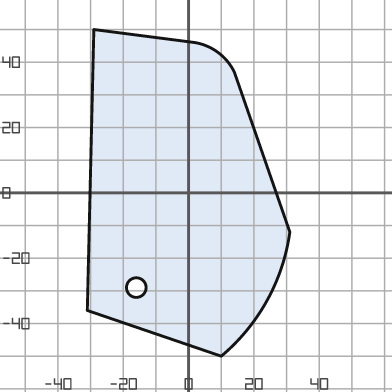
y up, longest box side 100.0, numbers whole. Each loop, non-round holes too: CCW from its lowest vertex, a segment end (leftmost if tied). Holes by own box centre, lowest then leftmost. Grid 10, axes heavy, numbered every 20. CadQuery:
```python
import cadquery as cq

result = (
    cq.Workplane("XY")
    .moveTo(10.0, -50.0)
    .threePointArc((24.0, -33.0), (31.0, -12.0))
    .lineTo(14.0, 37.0)
    .threePointArc((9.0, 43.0), (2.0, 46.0))
    .lineTo(-29.0, 50.0)
    .lineTo(-31.0, -36.0)
    .close()
    .moveTo(-16.0, -29.0)
    .circle(3.0)
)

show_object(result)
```